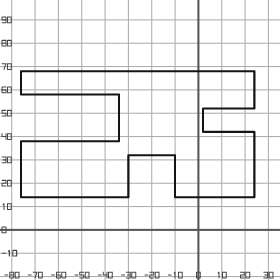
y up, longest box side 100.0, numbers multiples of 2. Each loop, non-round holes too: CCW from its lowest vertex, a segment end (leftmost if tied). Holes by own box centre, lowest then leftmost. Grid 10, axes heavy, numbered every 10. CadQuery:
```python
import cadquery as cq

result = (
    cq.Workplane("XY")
    .moveTo(-76.0, 14.0)
    .lineTo(-30.0, 14.0)
    .lineTo(-30.0, 32.0)
    .lineTo(-10.0, 32.0)
    .lineTo(-10.0, 14.0)
    .lineTo(24.0, 14.0)
    .lineTo(24.0, 42.0)
    .lineTo(2.0, 42.0)
    .lineTo(2.0, 52.0)
    .lineTo(24.0, 52.0)
    .lineTo(24.0, 68.0)
    .lineTo(-76.0, 68.0)
    .lineTo(-76.0, 58.0)
    .lineTo(-34.0, 58.0)
    .lineTo(-34.0, 38.0)
    .lineTo(-76.0, 38.0)
    .close()
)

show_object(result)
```